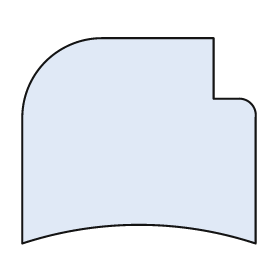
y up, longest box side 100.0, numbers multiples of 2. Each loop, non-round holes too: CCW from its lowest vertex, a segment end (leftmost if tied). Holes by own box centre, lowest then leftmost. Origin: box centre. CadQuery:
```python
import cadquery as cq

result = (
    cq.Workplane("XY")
    .moveTo(-50.0, -44.0)
    .threePointArc((0.0, -36.0), (50.0, -44.0))
    .lineTo(50.0, 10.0)
    .threePointArc((48.0, 16.0), (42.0, 18.0))
    .lineTo(32.0, 18.0)
    .lineTo(32.0, 44.0)
    .lineTo(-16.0, 44.0)
    .threePointArc((-40.0, 34.0), (-50.0, 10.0))
    .close()
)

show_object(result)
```